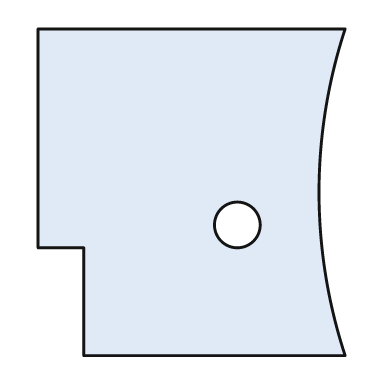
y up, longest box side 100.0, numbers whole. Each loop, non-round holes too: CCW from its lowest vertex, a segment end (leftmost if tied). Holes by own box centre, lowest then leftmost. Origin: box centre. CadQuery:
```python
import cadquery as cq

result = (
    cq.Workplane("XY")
    .moveTo(-33.0, -50.0)
    .lineTo(47.0, -50.0)
    .threePointArc((39.0, 0.0), (47.0, 50.0))
    .lineTo(-47.0, 50.0)
    .lineTo(-47.0, -17.0)
    .lineTo(-33.0, -17.0)
    .close()
    .moveTo(14.0, -10.0)
    .circle(7.0)
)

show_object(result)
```